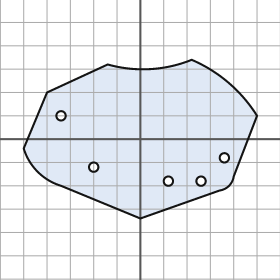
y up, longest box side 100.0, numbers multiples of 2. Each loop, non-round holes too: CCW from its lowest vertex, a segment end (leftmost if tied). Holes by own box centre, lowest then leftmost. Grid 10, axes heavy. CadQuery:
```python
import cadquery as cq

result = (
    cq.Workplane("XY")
    .moveTo(0.0, -34.0)
    .lineTo(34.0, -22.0)
    .threePointArc((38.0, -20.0), (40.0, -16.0))
    .lineTo(50.0, 10.0)
    .threePointArc((38.0, 24.0), (22.0, 34.0))
    .threePointArc((4.0, 30.0), (-14.0, 32.0))
    .lineTo(-40.0, 20.0)
    .lineTo(-50.0, -4.0)
    .threePointArc((-44.0, -14.0), (-34.0, -20.0))
    .close()
    .moveTo(12.0, -18.0)
    .circle(2.0)
    .moveTo(26.0, -18.0)
    .circle(2.0)
    .moveTo(-20.0, -12.0)
    .circle(2.0)
    .moveTo(36.0, -8.0)
    .circle(2.0)
    .moveTo(-34.0, 10.0)
    .circle(2.0)
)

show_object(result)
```